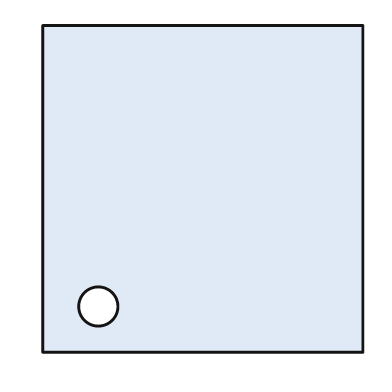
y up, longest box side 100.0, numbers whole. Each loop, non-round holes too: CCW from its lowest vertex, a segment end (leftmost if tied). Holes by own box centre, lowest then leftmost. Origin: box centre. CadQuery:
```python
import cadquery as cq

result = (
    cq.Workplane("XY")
    .moveTo(-49.0, -50.0)
    .lineTo(49.0, -50.0)
    .lineTo(49.0, 50.0)
    .lineTo(-49.0, 50.0)
    .close()
    .moveTo(-32.0, -36.0)
    .circle(6.0)
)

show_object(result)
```